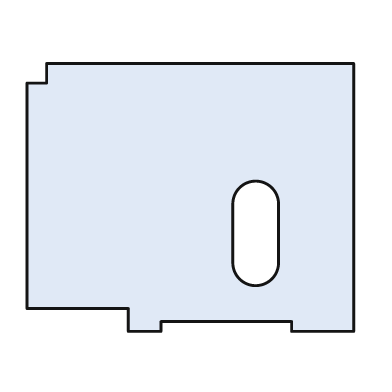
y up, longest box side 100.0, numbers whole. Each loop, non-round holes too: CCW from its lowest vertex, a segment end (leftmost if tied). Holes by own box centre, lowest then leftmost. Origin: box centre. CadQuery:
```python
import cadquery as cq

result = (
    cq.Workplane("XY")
    .moveTo(-19.0, -41.0)
    .lineTo(-9.0, -41.0)
    .lineTo(-9.0, -38.0)
    .lineTo(31.0, -38.0)
    .lineTo(31.0, -41.0)
    .lineTo(50.0, -41.0)
    .lineTo(50.0, 41.0)
    .lineTo(-44.0, 41.0)
    .lineTo(-44.0, 35.0)
    .lineTo(-50.0, 35.0)
    .lineTo(-50.0, -34.0)
    .lineTo(-19.0, -34.0)
    .close()
    .moveTo(13.0, -20.0)
    .threePointArc((20.0, -27.0), (27.0, -20.0))
    .lineTo(27.0, -2.0)
    .threePointArc((20.0, 5.0), (13.0, -2.0))
    .close()
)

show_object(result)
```